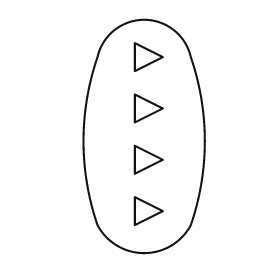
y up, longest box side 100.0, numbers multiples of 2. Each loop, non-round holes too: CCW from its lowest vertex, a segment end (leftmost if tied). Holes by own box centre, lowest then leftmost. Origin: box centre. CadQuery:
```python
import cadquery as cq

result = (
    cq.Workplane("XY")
    .moveTo(-20.0, -38.0)
    .threePointArc((0.0, -50.0), (20.0, -38.0))
    .threePointArc((26.0, -2.0), (20.0, 34.0))
    .threePointArc((0.0, 50.0), (-20.0, 34.0))
    .threePointArc((-26.0, -2.0), (-20.0, -38.0))
    .close()
    .moveTo(-4.0, -38.0)
    .lineTo(8.0, -32.0)
    .lineTo(-4.0, -26.0)
    .close()
    .moveTo(-4.0, -16.0)
    .lineTo(8.0, -10.0)
    .lineTo(-4.0, -4.0)
    .close()
    .moveTo(-4.0, 6.0)
    .lineTo(8.0, 12.0)
    .lineTo(-4.0, 18.0)
    .close()
    .moveTo(-4.0, 28.0)
    .lineTo(8.0, 34.0)
    .lineTo(-4.0, 40.0)
    .close()
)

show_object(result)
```